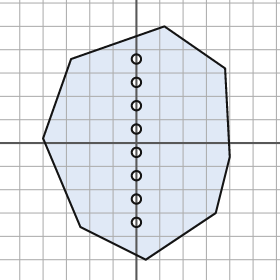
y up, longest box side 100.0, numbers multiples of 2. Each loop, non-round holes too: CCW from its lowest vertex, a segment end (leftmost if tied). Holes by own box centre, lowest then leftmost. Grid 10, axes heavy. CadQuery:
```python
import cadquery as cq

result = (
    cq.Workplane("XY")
    .moveTo(4.0, -50.0)
    .lineTo(34.0, -30.0)
    .lineTo(40.0, -6.0)
    .lineTo(38.0, 32.0)
    .lineTo(12.0, 50.0)
    .lineTo(-28.0, 36.0)
    .lineTo(-40.0, 2.0)
    .lineTo(-24.0, -36.0)
    .close()
    .moveTo(0.0, -34.0)
    .circle(2.0)
    .moveTo(0.0, -24.0)
    .circle(2.0)
    .moveTo(0.0, -14.0)
    .circle(2.0)
    .moveTo(0.0, -4.0)
    .circle(2.0)
    .moveTo(0.0, 6.0)
    .circle(2.0)
    .moveTo(0.0, 16.0)
    .circle(2.0)
    .moveTo(0.0, 26.0)
    .circle(2.0)
    .moveTo(0.0, 36.0)
    .circle(2.0)
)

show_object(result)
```